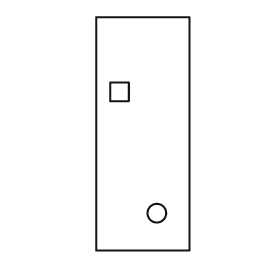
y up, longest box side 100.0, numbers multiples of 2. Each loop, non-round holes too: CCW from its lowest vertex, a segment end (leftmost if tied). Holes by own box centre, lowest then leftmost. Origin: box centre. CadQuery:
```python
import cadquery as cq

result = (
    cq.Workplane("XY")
    .moveTo(-20.0, -50.0)
    .lineTo(20.0, -50.0)
    .lineTo(20.0, 50.0)
    .lineTo(-20.0, 50.0)
    .close()
    .moveTo(6.0, -34.0)
    .circle(4.0)
    .moveTo(-14.0, 14.0)
    .lineTo(-6.0, 14.0)
    .lineTo(-6.0, 22.0)
    .lineTo(-14.0, 22.0)
    .close()
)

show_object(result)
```